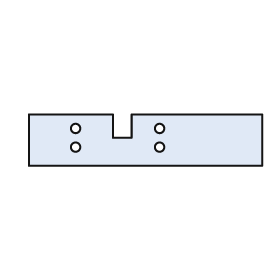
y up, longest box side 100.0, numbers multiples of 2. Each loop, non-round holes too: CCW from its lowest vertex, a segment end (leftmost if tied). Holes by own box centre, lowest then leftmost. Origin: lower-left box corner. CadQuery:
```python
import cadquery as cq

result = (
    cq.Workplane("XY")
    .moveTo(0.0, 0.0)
    .lineTo(100.0, 0.0)
    .lineTo(100.0, 22.0)
    .lineTo(44.0, 22.0)
    .lineTo(44.0, 12.0)
    .lineTo(36.0, 12.0)
    .lineTo(36.0, 22.0)
    .lineTo(0.0, 22.0)
    .close()
    .moveTo(20.0, 8.0)
    .circle(2.0)
    .moveTo(56.0, 8.0)
    .circle(2.0)
    .moveTo(20.0, 16.0)
    .circle(2.0)
    .moveTo(56.0, 16.0)
    .circle(2.0)
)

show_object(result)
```